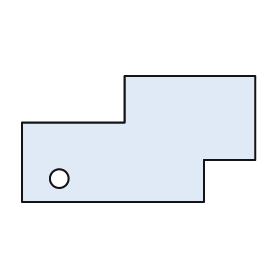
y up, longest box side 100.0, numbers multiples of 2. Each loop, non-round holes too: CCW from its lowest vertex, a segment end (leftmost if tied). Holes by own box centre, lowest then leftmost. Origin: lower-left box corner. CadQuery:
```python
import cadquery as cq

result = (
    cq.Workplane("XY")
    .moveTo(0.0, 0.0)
    .lineTo(78.0, 0.0)
    .lineTo(78.0, 18.0)
    .lineTo(100.0, 18.0)
    .lineTo(100.0, 54.0)
    .lineTo(44.0, 54.0)
    .lineTo(44.0, 34.0)
    .lineTo(0.0, 34.0)
    .close()
    .moveTo(16.0, 10.0)
    .circle(4.0)
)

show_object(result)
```